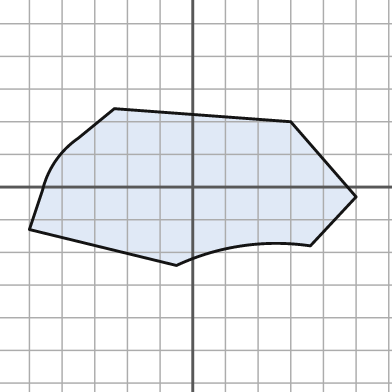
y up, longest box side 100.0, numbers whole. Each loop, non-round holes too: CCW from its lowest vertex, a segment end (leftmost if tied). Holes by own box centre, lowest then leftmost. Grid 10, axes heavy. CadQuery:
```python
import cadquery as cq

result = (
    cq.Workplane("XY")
    .moveTo(-5.0, -24.0)
    .threePointArc((15.0, -18.0), (36.0, -18.0))
    .lineTo(50.0, -3.0)
    .lineTo(30.0, 20.0)
    .lineTo(-24.0, 24.0)
    .lineTo(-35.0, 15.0)
    .threePointArc((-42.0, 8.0), (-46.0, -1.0))
    .lineTo(-50.0, -13.0)
    .close()
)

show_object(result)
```